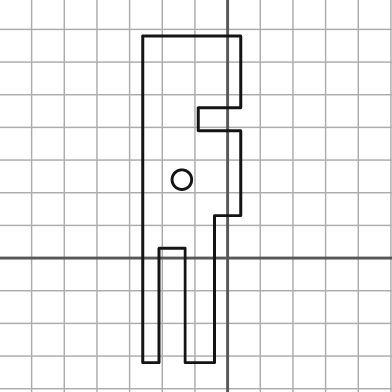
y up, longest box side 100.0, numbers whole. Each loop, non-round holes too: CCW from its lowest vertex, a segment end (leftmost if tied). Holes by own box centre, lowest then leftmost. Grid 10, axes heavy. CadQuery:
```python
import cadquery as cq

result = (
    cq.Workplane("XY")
    .moveTo(-26.0, -32.0)
    .lineTo(-21.0, -32.0)
    .lineTo(-21.0, 3.0)
    .lineTo(-13.0, 3.0)
    .lineTo(-13.0, -32.0)
    .lineTo(-4.0, -32.0)
    .lineTo(-4.0, 13.0)
    .lineTo(4.0, 13.0)
    .lineTo(4.0, 39.0)
    .lineTo(-9.0, 39.0)
    .lineTo(-9.0, 46.0)
    .lineTo(4.0, 46.0)
    .lineTo(4.0, 68.0)
    .lineTo(-26.0, 68.0)
    .close()
    .moveTo(-14.0, 24.0)
    .circle(3.0)
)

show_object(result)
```